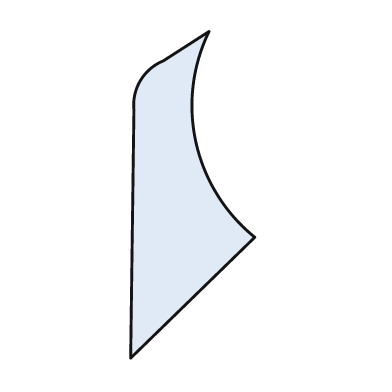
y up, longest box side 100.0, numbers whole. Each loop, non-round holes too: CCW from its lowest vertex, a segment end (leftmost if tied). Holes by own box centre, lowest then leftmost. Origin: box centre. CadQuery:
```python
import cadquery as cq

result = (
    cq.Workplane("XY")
    .moveTo(-19.0, -50.0)
    .lineTo(19.0, -13.0)
    .threePointArc((1.0, 16.0), (5.0, 50.0))
    .lineTo(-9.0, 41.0)
    .threePointArc((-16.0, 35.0), (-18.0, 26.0))
    .close()
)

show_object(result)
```